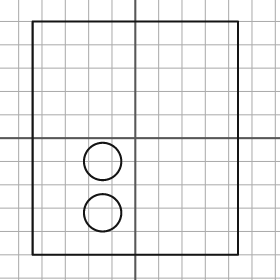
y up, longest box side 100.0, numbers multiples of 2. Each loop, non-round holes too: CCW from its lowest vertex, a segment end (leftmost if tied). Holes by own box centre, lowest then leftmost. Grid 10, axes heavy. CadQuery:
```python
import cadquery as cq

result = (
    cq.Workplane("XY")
    .moveTo(-44.0, -50.0)
    .lineTo(44.0, -50.0)
    .lineTo(44.0, 50.0)
    .lineTo(-44.0, 50.0)
    .close()
    .moveTo(-14.0, -32.0)
    .circle(8.0)
    .moveTo(-14.0, -10.0)
    .circle(8.0)
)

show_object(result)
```